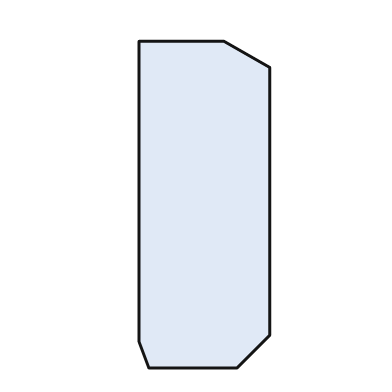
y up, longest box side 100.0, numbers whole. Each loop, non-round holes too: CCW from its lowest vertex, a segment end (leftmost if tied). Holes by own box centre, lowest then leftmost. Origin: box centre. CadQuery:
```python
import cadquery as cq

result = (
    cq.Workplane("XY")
    .moveTo(-17.0, -50.0)
    .lineTo(10.0, -50.0)
    .lineTo(20.0, -40.0)
    .lineTo(20.0, 42.0)
    .lineTo(6.0, 50.0)
    .lineTo(-20.0, 50.0)
    .lineTo(-20.0, -42.0)
    .close()
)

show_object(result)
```